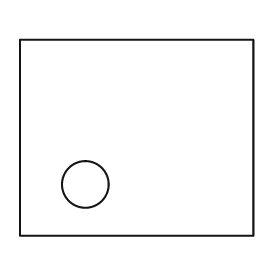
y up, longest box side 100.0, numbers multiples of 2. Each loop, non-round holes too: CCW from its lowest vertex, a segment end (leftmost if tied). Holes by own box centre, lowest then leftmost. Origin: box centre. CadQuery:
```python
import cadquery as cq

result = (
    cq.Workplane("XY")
    .moveTo(-50.0, -42.0)
    .lineTo(50.0, -42.0)
    .lineTo(50.0, 42.0)
    .lineTo(-50.0, 42.0)
    .close()
    .moveTo(-22.0, -20.0)
    .circle(10.0)
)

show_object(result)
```